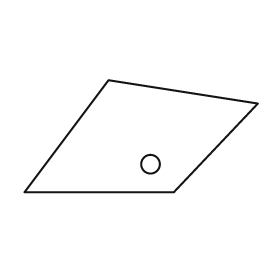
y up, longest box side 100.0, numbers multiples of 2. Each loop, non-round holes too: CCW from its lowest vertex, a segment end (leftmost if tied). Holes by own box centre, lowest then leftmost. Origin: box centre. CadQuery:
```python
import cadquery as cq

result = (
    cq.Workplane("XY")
    .moveTo(-50.0, -24.0)
    .lineTo(14.0, -24.0)
    .lineTo(50.0, 14.0)
    .lineTo(-14.0, 24.0)
    .close()
    .moveTo(4.0, -12.0)
    .circle(4.0)
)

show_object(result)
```